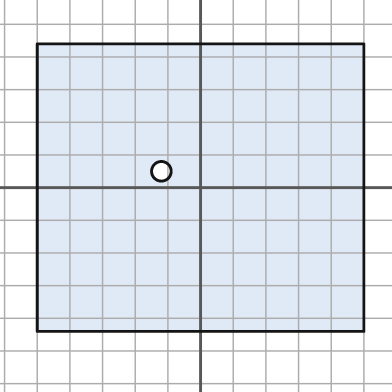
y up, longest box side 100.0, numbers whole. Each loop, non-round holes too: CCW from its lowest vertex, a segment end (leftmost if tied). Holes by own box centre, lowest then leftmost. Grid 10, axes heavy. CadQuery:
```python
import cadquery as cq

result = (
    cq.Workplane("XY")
    .moveTo(-50.0, -44.0)
    .lineTo(50.0, -44.0)
    .lineTo(50.0, 44.0)
    .lineTo(-50.0, 44.0)
    .close()
    .moveTo(-12.0, 5.0)
    .circle(3.0)
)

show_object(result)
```